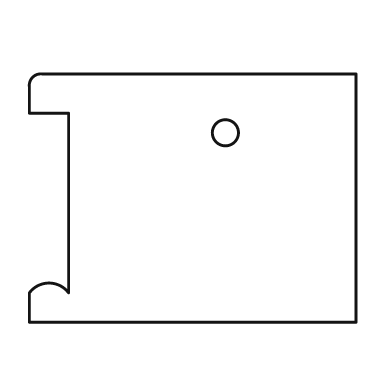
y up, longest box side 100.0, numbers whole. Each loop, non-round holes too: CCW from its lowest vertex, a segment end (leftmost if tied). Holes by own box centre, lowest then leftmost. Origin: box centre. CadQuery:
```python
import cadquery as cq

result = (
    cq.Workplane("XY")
    .moveTo(-50.0, -38.0)
    .lineTo(50.0, -38.0)
    .lineTo(50.0, 38.0)
    .lineTo(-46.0, 38.0)
    .threePointArc((-49.0, 37.0), (-50.0, 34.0))
    .lineTo(-50.0, 26.0)
    .lineTo(-38.0, 26.0)
    .lineTo(-38.0, -29.0)
    .threePointArc((-44.0, -26.0), (-50.0, -29.0))
    .close()
    .moveTo(10.0, 20.0)
    .circle(4.0)
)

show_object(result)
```